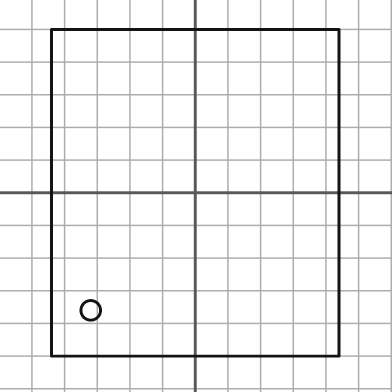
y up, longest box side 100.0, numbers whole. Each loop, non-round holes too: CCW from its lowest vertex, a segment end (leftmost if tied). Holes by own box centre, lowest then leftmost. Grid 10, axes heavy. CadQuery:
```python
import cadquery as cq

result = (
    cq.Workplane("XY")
    .moveTo(-44.0, -50.0)
    .lineTo(44.0, -50.0)
    .lineTo(44.0, 50.0)
    .lineTo(-44.0, 50.0)
    .close()
    .moveTo(-32.0, -36.0)
    .circle(3.0)
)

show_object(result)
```